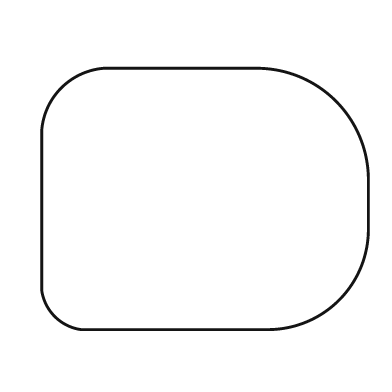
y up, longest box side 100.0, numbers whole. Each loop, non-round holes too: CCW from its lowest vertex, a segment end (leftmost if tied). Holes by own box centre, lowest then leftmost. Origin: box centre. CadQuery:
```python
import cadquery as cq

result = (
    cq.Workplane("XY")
    .moveTo(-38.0, -40.0)
    .lineTo(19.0, -40.0)
    .threePointArc((41.0, -31.0), (50.0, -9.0))
    .lineTo(50.0, 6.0)
    .threePointArc((40.0, 30.0), (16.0, 40.0))
    .lineTo(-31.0, 40.0)
    .threePointArc((-44.0, 34.0), (-50.0, 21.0))
    .lineTo(-50.0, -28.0)
    .threePointArc((-46.0, -36.0), (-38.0, -40.0))
    .close()
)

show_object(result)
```